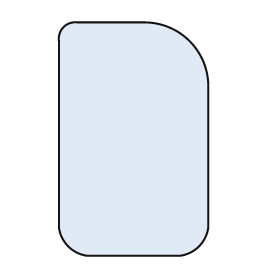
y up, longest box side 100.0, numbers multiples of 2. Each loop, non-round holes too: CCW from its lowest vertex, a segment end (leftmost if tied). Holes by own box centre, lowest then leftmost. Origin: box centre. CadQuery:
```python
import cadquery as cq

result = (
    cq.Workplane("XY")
    .moveTo(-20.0, -50.0)
    .lineTo(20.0, -50.0)
    .threePointArc((28.0, -46.0), (32.0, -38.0))
    .lineTo(32.0, 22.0)
    .threePointArc((24.0, 42.0), (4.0, 50.0))
    .lineTo(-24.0, 50.0)
    .threePointArc((-30.0, 48.0), (-32.0, 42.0))
    .lineTo(-32.0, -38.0)
    .threePointArc((-28.0, -46.0), (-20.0, -50.0))
    .close()
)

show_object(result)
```